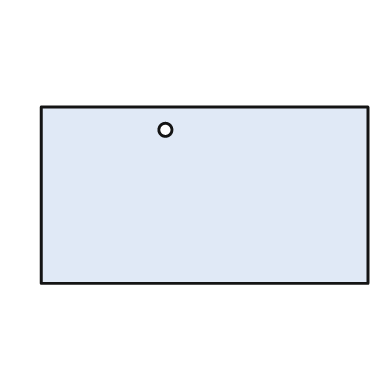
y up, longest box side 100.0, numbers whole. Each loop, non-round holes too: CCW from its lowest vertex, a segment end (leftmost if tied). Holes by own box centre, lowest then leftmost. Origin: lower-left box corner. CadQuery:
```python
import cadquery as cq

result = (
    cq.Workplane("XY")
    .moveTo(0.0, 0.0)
    .lineTo(100.0, 0.0)
    .lineTo(100.0, 54.0)
    .lineTo(0.0, 54.0)
    .close()
    .moveTo(38.0, 47.0)
    .circle(2.0)
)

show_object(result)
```